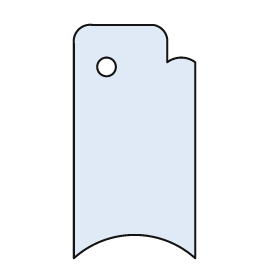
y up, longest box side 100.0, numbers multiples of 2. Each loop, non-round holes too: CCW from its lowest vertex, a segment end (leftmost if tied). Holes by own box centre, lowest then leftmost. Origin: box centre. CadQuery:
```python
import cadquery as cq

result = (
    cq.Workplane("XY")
    .moveTo(-26.0, -50.0)
    .threePointArc((0.0, -40.0), (26.0, -50.0))
    .lineTo(26.0, 34.0)
    .threePointArc((20.0, 36.0), (14.0, 34.0))
    .lineTo(14.0, 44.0)
    .threePointArc((12.0, 48.0), (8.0, 50.0))
    .lineTo(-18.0, 50.0)
    .threePointArc((-24.0, 48.0), (-26.0, 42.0))
    .close()
    .moveTo(-12.0, 32.0)
    .circle(4.0)
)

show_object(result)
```